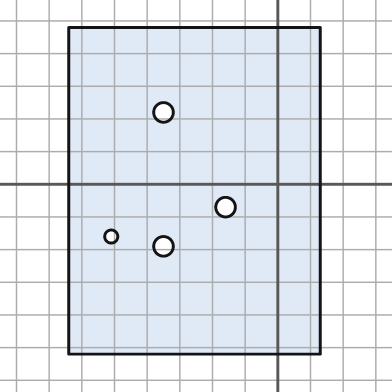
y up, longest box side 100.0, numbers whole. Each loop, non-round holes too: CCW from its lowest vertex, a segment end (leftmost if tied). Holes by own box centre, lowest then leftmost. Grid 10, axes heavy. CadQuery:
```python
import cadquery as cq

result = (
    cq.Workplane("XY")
    .moveTo(-64.0, -52.0)
    .lineTo(13.0, -52.0)
    .lineTo(13.0, 48.0)
    .lineTo(-64.0, 48.0)
    .close()
    .moveTo(-35.0, -19.0)
    .circle(3.0)
    .moveTo(-51.0, -16.0)
    .circle(2.0)
    .moveTo(-16.0, -7.0)
    .circle(3.0)
    .moveTo(-35.0, 22.0)
    .circle(3.0)
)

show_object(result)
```